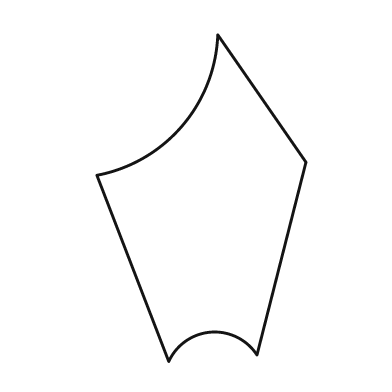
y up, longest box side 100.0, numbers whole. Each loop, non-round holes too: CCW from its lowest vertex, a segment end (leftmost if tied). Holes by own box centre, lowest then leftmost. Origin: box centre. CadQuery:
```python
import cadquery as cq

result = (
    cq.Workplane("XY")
    .moveTo(-10.0, -50.0)
    .threePointArc((3.0, -41.0), (17.0, -48.0))
    .lineTo(32.0, 11.0)
    .lineTo(5.0, 50.0)
    .threePointArc((-6.0, 22.0), (-32.0, 7.0))
    .close()
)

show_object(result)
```